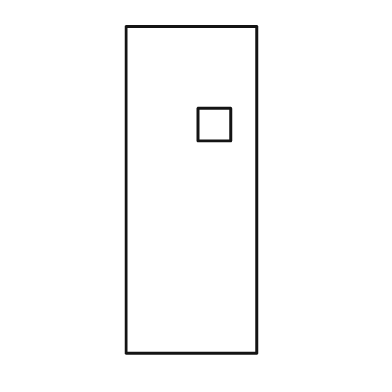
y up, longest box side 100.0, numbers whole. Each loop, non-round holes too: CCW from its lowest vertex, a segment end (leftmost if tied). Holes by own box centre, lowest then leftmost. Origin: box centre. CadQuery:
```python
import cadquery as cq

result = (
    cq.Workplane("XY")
    .moveTo(-20.0, -50.0)
    .lineTo(20.0, -50.0)
    .lineTo(20.0, 50.0)
    .lineTo(-20.0, 50.0)
    .close()
    .moveTo(2.0, 15.0)
    .lineTo(12.0, 15.0)
    .lineTo(12.0, 25.0)
    .lineTo(2.0, 25.0)
    .close()
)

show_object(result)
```